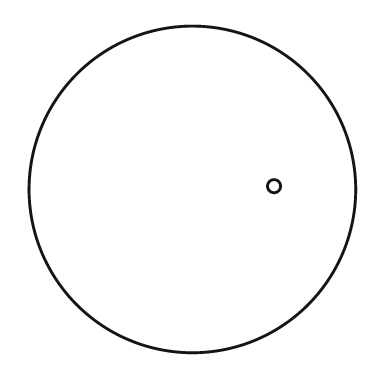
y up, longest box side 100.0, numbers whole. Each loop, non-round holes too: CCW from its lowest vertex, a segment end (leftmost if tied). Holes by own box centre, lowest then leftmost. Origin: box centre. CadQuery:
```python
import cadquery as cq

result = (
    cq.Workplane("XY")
    .moveTo(0.0, 0.0)
    .circle(50.0)
    .moveTo(25.0, 1.0)
    .circle(2.0)
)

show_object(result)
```